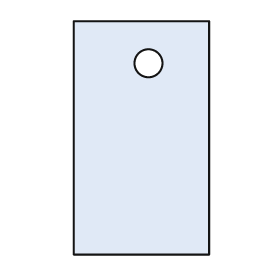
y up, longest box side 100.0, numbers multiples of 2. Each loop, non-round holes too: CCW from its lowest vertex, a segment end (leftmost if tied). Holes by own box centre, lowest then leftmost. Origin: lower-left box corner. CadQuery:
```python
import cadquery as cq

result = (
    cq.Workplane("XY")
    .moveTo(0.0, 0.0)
    .lineTo(58.0, 0.0)
    .lineTo(58.0, 100.0)
    .lineTo(0.0, 100.0)
    .close()
    .moveTo(32.0, 82.0)
    .circle(6.0)
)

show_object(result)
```